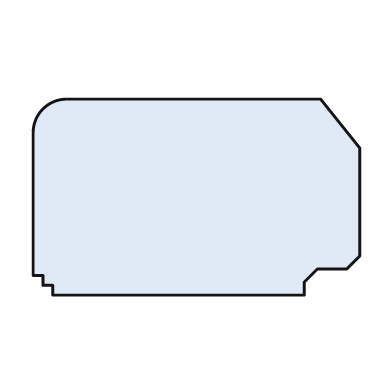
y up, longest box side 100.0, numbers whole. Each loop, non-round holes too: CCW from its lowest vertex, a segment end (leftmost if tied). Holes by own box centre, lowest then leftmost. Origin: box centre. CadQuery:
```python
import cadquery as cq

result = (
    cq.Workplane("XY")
    .moveTo(-44.0, -30.0)
    .lineTo(33.0, -30.0)
    .lineTo(33.0, -26.0)
    .lineTo(37.0, -22.0)
    .lineTo(46.0, -22.0)
    .lineTo(50.0, -18.0)
    .lineTo(50.0, 15.0)
    .lineTo(38.0, 30.0)
    .lineTo(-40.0, 30.0)
    .threePointArc((-47.0, 27.0), (-50.0, 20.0))
    .lineTo(-50.0, -24.0)
    .lineTo(-47.0, -24.0)
    .lineTo(-47.0, -27.0)
    .lineTo(-44.0, -27.0)
    .close()
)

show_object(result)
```